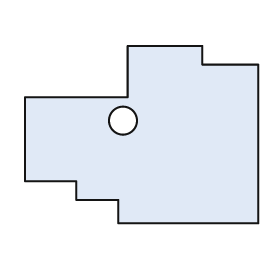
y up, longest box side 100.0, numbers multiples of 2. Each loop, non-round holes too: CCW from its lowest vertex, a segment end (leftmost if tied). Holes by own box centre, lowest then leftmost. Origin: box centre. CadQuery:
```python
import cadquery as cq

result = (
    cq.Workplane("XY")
    .moveTo(-10.0, -38.0)
    .lineTo(50.0, -38.0)
    .lineTo(50.0, 30.0)
    .lineTo(26.0, 30.0)
    .lineTo(26.0, 38.0)
    .lineTo(-6.0, 38.0)
    .lineTo(-6.0, 16.0)
    .lineTo(-50.0, 16.0)
    .lineTo(-50.0, -20.0)
    .lineTo(-28.0, -20.0)
    .lineTo(-28.0, -28.0)
    .lineTo(-10.0, -28.0)
    .close()
    .moveTo(-8.0, 6.0)
    .circle(6.0)
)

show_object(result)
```